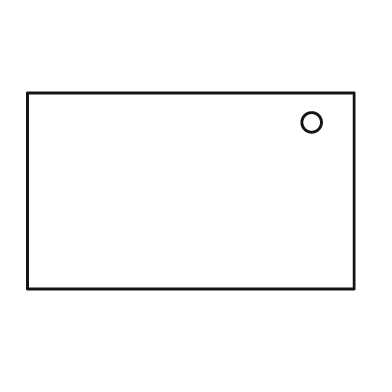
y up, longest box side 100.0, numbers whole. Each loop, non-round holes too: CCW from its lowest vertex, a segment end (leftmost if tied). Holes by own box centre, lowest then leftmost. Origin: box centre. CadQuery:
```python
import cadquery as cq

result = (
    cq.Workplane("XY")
    .moveTo(-50.0, -30.0)
    .lineTo(50.0, -30.0)
    .lineTo(50.0, 30.0)
    .lineTo(-50.0, 30.0)
    .close()
    .moveTo(37.0, 21.0)
    .circle(3.0)
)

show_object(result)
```